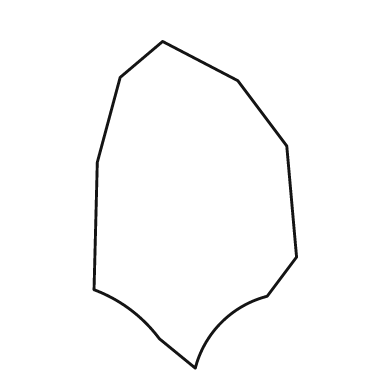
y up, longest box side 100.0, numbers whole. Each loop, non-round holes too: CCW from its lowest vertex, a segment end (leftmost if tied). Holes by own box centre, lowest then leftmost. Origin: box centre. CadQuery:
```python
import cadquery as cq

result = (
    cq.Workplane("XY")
    .moveTo(0.0, -50.0)
    .threePointArc((8.0, -36.0), (22.0, -28.0))
    .lineTo(31.0, -16.0)
    .lineTo(28.0, 18.0)
    .lineTo(13.0, 38.0)
    .lineTo(-10.0, 50.0)
    .lineTo(-23.0, 39.0)
    .lineTo(-30.0, 13.0)
    .lineTo(-31.0, -26.0)
    .threePointArc((-20.0, -32.0), (-11.0, -41.0))
    .close()
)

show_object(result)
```